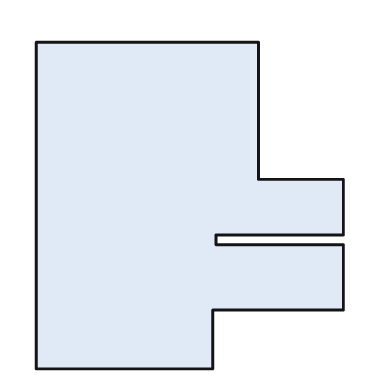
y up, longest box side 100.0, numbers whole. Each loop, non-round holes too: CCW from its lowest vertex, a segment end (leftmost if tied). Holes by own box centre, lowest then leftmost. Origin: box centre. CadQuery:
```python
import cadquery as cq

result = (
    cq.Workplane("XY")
    .moveTo(-47.0, -50.0)
    .lineTo(7.0, -50.0)
    .lineTo(7.0, -32.0)
    .lineTo(47.0, -32.0)
    .lineTo(47.0, -12.0)
    .lineTo(8.0, -12.0)
    .lineTo(8.0, -9.0)
    .lineTo(47.0, -9.0)
    .lineTo(47.0, 8.0)
    .lineTo(21.0, 8.0)
    .lineTo(21.0, 50.0)
    .lineTo(-47.0, 50.0)
    .close()
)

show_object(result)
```